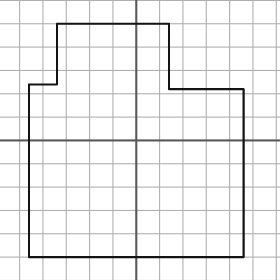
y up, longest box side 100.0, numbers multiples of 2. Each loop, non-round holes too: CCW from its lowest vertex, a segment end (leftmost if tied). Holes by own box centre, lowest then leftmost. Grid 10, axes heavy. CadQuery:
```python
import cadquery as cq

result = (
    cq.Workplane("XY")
    .moveTo(-46.0, -50.0)
    .lineTo(46.0, -50.0)
    .lineTo(46.0, 22.0)
    .lineTo(14.0, 22.0)
    .lineTo(14.0, 50.0)
    .lineTo(-34.0, 50.0)
    .lineTo(-34.0, 24.0)
    .lineTo(-46.0, 24.0)
    .close()
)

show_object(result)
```